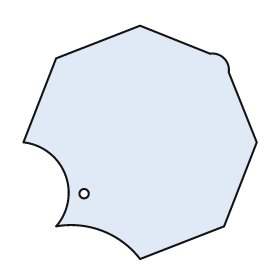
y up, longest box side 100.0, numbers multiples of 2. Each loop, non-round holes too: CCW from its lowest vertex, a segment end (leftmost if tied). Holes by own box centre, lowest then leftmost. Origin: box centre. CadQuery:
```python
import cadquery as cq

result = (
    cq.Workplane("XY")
    .moveTo(0.0, -50.0)
    .lineTo(36.0, -36.0)
    .lineTo(50.0, 0.0)
    .lineTo(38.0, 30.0)
    .threePointArc((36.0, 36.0), (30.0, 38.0))
    .lineTo(0.0, 50.0)
    .lineTo(-36.0, 36.0)
    .lineTo(-50.0, 0.0)
    .threePointArc((-32.0, -14.0), (-36.0, -36.0))
    .threePointArc((-16.0, -38.0), (0.0, -50.0))
    .close()
    .moveTo(-24.0, -22.0)
    .circle(2.0)
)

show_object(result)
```